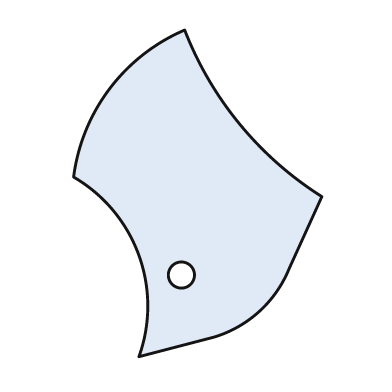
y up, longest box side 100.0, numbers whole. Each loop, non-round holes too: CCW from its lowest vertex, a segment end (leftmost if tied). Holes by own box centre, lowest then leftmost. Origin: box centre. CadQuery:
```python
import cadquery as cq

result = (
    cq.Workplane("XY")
    .moveTo(-18.0, -50.0)
    .lineTo(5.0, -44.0)
    .threePointArc((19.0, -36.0), (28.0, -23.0))
    .lineTo(38.0, -1.0)
    .threePointArc((13.0, 21.0), (-4.0, 50.0))
    .threePointArc((-27.0, 32.0), (-38.0, 5.0))
    .threePointArc((-18.0, -19.0), (-18.0, -50.0))
    .close()
    .moveTo(-5.0, -25.0)
    .circle(4.0)
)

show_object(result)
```